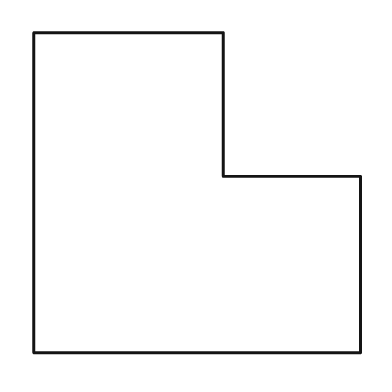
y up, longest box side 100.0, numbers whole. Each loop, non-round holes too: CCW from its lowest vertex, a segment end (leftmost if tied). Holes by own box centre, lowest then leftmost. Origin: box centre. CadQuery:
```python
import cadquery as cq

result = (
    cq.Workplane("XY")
    .moveTo(-50.0, -49.0)
    .lineTo(50.0, -49.0)
    .lineTo(50.0, 5.0)
    .lineTo(8.0, 5.0)
    .lineTo(8.0, 49.0)
    .lineTo(-50.0, 49.0)
    .close()
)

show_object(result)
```